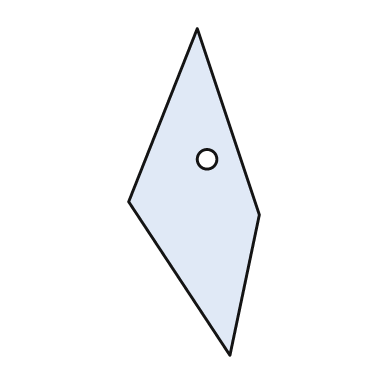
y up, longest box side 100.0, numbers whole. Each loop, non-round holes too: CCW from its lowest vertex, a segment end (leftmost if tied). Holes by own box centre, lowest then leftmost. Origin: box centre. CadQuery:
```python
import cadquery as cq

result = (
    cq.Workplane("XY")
    .moveTo(11.0, -50.0)
    .lineTo(20.0, -7.0)
    .lineTo(1.0, 50.0)
    .lineTo(-20.0, -3.0)
    .close()
    .moveTo(4.0, 10.0)
    .circle(3.0)
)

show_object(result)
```